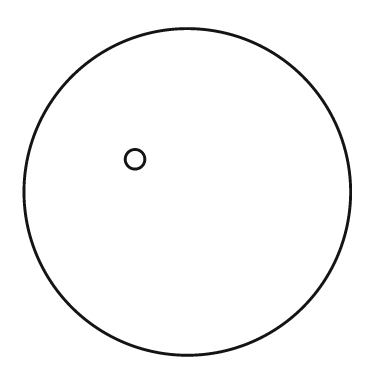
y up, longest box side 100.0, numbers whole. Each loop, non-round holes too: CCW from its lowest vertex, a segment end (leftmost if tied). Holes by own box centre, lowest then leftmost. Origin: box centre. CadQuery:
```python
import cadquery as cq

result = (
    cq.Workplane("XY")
    .moveTo(0.0, 0.0)
    .circle(50.0)
    .moveTo(-16.0, 10.0)
    .circle(3.0)
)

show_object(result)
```